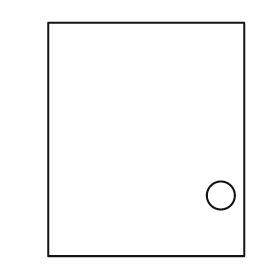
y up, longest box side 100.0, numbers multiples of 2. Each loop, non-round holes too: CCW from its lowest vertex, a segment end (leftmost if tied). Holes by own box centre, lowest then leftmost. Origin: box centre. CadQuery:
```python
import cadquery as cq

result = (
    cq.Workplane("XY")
    .moveTo(-42.0, -50.0)
    .lineTo(42.0, -50.0)
    .lineTo(42.0, 50.0)
    .lineTo(-42.0, 50.0)
    .close()
    .moveTo(32.0, -24.0)
    .circle(6.0)
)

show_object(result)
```